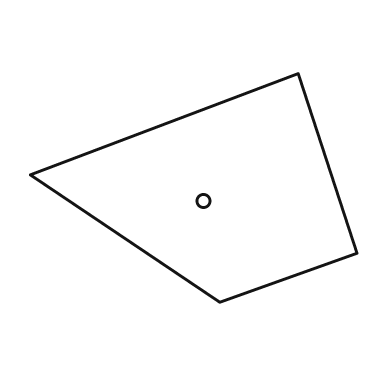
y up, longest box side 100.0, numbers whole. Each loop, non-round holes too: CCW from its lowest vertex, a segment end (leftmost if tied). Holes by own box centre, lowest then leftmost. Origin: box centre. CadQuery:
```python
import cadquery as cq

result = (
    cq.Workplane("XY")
    .moveTo(8.0, -35.0)
    .lineTo(50.0, -20.0)
    .lineTo(32.0, 35.0)
    .lineTo(-50.0, 4.0)
    .close()
    .moveTo(3.0, -4.0)
    .circle(2.0)
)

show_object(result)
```